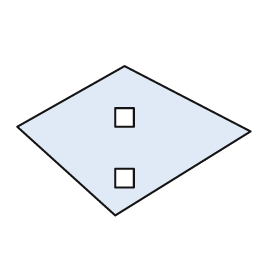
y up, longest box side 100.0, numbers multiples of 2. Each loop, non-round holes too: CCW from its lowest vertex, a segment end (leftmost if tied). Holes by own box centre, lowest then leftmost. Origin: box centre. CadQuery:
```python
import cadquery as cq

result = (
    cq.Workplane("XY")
    .moveTo(-8.0, -32.0)
    .lineTo(50.0, 4.0)
    .lineTo(-4.0, 32.0)
    .lineTo(-50.0, 6.0)
    .close()
    .moveTo(-8.0, -20.0)
    .lineTo(0.0, -20.0)
    .lineTo(0.0, -12.0)
    .lineTo(-8.0, -12.0)
    .close()
    .moveTo(-8.0, 6.0)
    .lineTo(0.0, 6.0)
    .lineTo(0.0, 14.0)
    .lineTo(-8.0, 14.0)
    .close()
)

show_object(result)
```